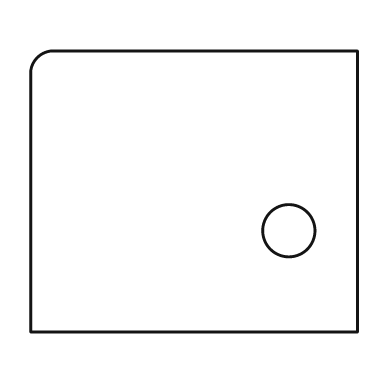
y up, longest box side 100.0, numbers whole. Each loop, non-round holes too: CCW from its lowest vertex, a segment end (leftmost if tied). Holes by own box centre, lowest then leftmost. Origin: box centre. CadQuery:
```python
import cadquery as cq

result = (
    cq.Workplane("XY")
    .moveTo(-50.0, -43.0)
    .lineTo(50.0, -43.0)
    .lineTo(50.0, 43.0)
    .lineTo(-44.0, 43.0)
    .threePointArc((-48.0, 41.0), (-50.0, 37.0))
    .close()
    .moveTo(29.0, -12.0)
    .circle(8.0)
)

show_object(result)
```